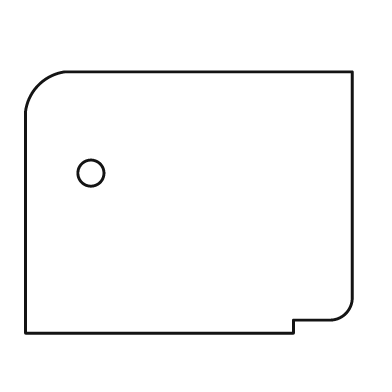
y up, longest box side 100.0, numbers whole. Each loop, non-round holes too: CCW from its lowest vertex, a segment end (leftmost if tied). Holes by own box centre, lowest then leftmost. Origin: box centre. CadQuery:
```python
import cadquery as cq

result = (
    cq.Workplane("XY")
    .moveTo(-50.0, -40.0)
    .lineTo(32.0, -40.0)
    .lineTo(32.0, -36.0)
    .lineTo(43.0, -36.0)
    .threePointArc((48.0, -34.0), (50.0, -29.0))
    .lineTo(50.0, 40.0)
    .lineTo(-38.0, 40.0)
    .threePointArc((-46.0, 36.0), (-50.0, 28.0))
    .close()
    .moveTo(-30.0, 9.0)
    .circle(4.0)
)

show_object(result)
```